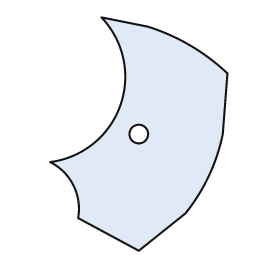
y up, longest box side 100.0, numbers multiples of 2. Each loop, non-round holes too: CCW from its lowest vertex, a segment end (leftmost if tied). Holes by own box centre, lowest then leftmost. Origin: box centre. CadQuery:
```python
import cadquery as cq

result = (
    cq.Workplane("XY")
    .moveTo(0.0, -50.0)
    .lineTo(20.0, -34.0)
    .threePointArc((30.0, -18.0), (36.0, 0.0))
    .lineTo(38.0, 26.0)
    .threePointArc((22.0, 38.0), (4.0, 46.0))
    .lineTo(-16.0, 50.0)
    .threePointArc((-8.0, 12.0), (-38.0, -12.0))
    .threePointArc((-28.0, -22.0), (-26.0, -36.0))
    .close()
    .moveTo(0.0, 0.0)
    .circle(4.0)
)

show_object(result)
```